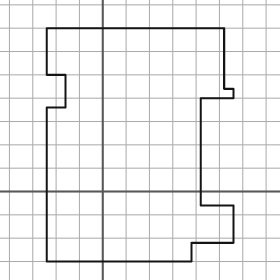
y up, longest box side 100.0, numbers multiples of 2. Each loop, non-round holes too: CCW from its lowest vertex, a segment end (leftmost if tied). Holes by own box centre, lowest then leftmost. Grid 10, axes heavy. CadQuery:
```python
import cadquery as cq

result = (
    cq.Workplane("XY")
    .moveTo(-24.0, -30.0)
    .lineTo(38.0, -30.0)
    .lineTo(38.0, -22.0)
    .lineTo(56.0, -22.0)
    .lineTo(56.0, -6.0)
    .lineTo(42.0, -6.0)
    .lineTo(42.0, 40.0)
    .lineTo(56.0, 40.0)
    .lineTo(56.0, 44.0)
    .lineTo(52.0, 44.0)
    .lineTo(52.0, 70.0)
    .lineTo(-24.0, 70.0)
    .lineTo(-24.0, 50.0)
    .lineTo(-16.0, 50.0)
    .lineTo(-16.0, 36.0)
    .lineTo(-24.0, 36.0)
    .close()
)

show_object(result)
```